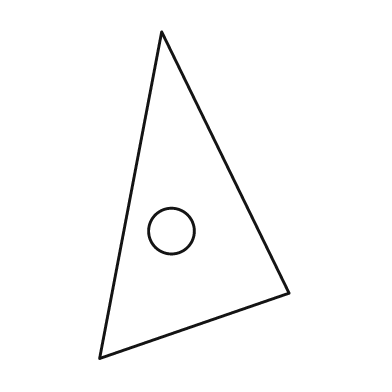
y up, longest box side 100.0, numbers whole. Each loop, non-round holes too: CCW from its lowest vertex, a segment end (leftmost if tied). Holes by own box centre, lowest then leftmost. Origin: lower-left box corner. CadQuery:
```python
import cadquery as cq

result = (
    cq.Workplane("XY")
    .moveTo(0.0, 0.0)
    .lineTo(58.0, 20.0)
    .lineTo(19.0, 100.0)
    .close()
    .moveTo(22.0, 39.0)
    .circle(7.0)
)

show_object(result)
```